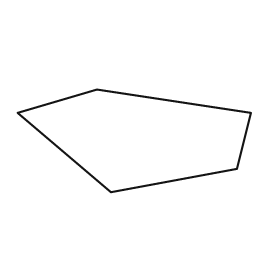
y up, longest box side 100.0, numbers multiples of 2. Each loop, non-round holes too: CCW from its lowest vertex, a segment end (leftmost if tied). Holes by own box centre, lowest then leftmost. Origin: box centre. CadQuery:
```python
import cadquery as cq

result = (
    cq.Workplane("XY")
    .moveTo(-10.0, -22.0)
    .lineTo(44.0, -12.0)
    .lineTo(50.0, 12.0)
    .lineTo(-16.0, 22.0)
    .lineTo(-50.0, 12.0)
    .close()
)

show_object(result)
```